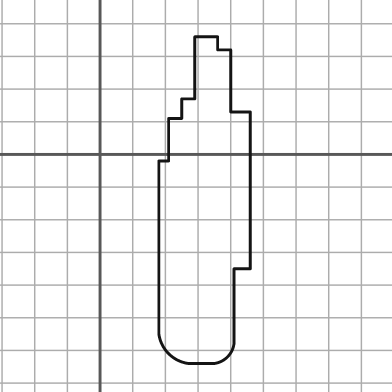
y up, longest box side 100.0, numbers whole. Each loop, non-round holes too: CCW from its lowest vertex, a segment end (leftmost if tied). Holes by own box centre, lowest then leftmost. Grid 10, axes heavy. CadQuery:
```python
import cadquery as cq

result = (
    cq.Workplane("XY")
    .moveTo(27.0, -64.0)
    .lineTo(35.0, -64.0)
    .threePointArc((39.0, -62.0), (41.0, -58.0))
    .lineTo(41.0, -35.0)
    .lineTo(46.0, -35.0)
    .lineTo(46.0, 13.0)
    .lineTo(40.0, 13.0)
    .lineTo(40.0, 32.0)
    .lineTo(36.0, 32.0)
    .lineTo(36.0, 36.0)
    .lineTo(29.0, 36.0)
    .lineTo(29.0, 17.0)
    .lineTo(25.0, 17.0)
    .lineTo(25.0, 11.0)
    .lineTo(21.0, 11.0)
    .lineTo(21.0, -2.0)
    .lineTo(18.0, -2.0)
    .lineTo(18.0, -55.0)
    .threePointArc((21.0, -61.0), (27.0, -64.0))
    .close()
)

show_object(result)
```